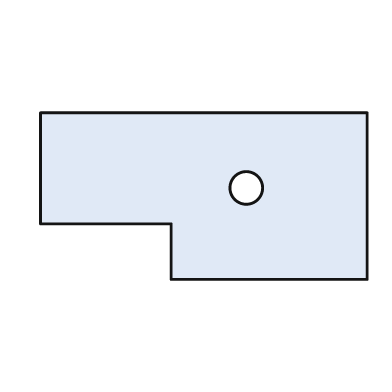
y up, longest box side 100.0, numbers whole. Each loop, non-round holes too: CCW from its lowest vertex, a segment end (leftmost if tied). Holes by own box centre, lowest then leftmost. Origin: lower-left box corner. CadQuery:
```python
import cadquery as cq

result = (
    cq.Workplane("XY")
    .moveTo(40.0, 0.0)
    .lineTo(100.0, 0.0)
    .lineTo(100.0, 51.0)
    .lineTo(0.0, 51.0)
    .lineTo(0.0, 17.0)
    .lineTo(40.0, 17.0)
    .close()
    .moveTo(63.0, 28.0)
    .circle(5.0)
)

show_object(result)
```